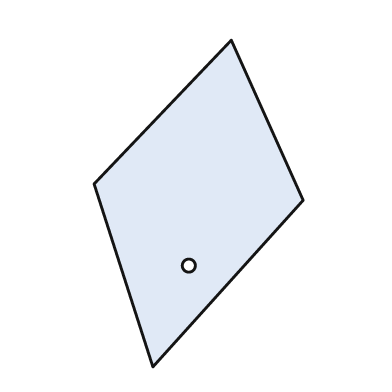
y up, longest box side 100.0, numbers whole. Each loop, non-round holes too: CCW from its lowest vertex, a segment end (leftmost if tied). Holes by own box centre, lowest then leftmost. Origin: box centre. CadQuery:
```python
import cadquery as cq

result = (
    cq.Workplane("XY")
    .moveTo(-14.0, -50.0)
    .lineTo(32.0, 1.0)
    .lineTo(10.0, 50.0)
    .lineTo(-32.0, 6.0)
    .close()
    .moveTo(-3.0, -19.0)
    .circle(2.0)
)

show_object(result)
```